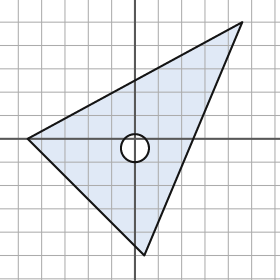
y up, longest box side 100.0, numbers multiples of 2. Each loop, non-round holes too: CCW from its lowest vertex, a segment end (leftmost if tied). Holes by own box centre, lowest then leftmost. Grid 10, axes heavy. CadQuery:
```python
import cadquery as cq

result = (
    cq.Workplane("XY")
    .moveTo(4.0, -50.0)
    .lineTo(46.0, 50.0)
    .lineTo(-46.0, 0.0)
    .close()
    .moveTo(0.0, -4.0)
    .circle(6.0)
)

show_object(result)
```